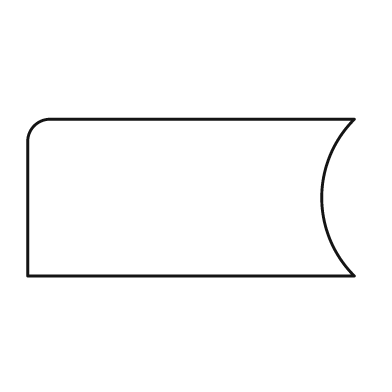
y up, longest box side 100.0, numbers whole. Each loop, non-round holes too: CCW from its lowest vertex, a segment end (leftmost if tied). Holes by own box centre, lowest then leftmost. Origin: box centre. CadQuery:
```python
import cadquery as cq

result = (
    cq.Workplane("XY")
    .moveTo(-50.0, -24.0)
    .lineTo(50.0, -24.0)
    .threePointArc((40.0, 0.0), (50.0, 24.0))
    .lineTo(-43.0, 24.0)
    .threePointArc((-48.0, 22.0), (-50.0, 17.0))
    .close()
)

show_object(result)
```